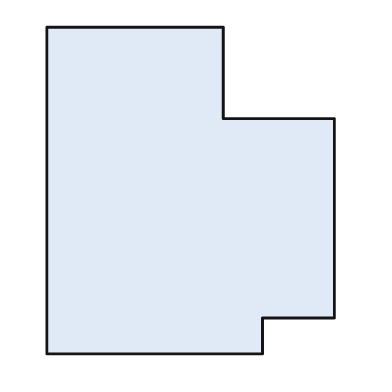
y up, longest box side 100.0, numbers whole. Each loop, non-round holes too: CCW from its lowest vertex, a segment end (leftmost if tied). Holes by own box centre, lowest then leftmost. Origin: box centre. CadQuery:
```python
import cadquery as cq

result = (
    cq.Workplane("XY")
    .moveTo(-44.0, -50.0)
    .lineTo(22.0, -50.0)
    .lineTo(22.0, -39.0)
    .lineTo(44.0, -39.0)
    .lineTo(44.0, 22.0)
    .lineTo(10.0, 22.0)
    .lineTo(10.0, 50.0)
    .lineTo(-44.0, 50.0)
    .close()
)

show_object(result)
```